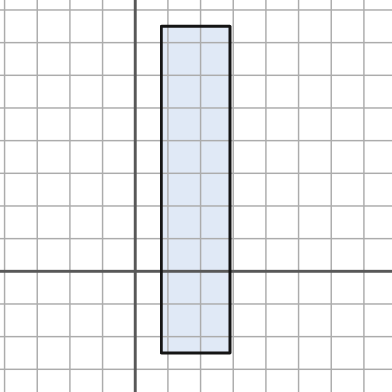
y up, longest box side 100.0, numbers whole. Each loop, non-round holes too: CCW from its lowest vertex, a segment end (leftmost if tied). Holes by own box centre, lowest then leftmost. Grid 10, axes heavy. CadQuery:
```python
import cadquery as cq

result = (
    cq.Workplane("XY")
    .moveTo(8.0, -25.0)
    .lineTo(29.0, -25.0)
    .lineTo(29.0, 75.0)
    .lineTo(8.0, 75.0)
    .close()
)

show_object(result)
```